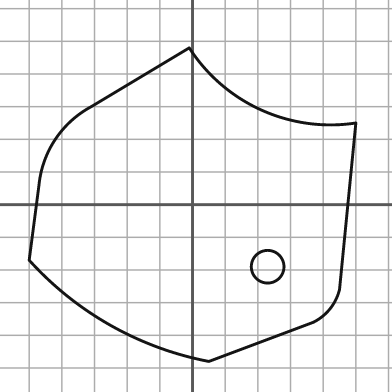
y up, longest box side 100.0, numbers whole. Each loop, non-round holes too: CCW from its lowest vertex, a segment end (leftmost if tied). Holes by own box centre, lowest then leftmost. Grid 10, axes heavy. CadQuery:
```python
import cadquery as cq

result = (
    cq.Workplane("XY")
    .moveTo(5.0, -48.0)
    .lineTo(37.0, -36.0)
    .threePointArc((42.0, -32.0), (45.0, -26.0))
    .lineTo(50.0, 25.0)
    .threePointArc((21.0, 29.0), (-1.0, 48.0))
    .lineTo(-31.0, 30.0)
    .threePointArc((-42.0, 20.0), (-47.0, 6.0))
    .lineTo(-50.0, -17.0)
    .threePointArc((-25.0, -37.0), (5.0, -48.0))
    .close()
    .moveTo(23.0, -19.0)
    .circle(5.0)
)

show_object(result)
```